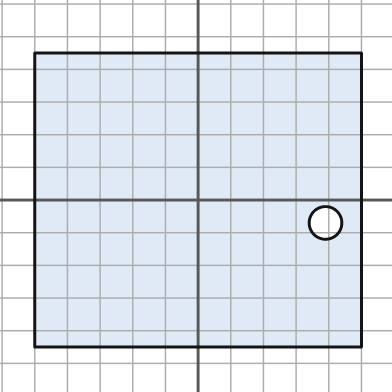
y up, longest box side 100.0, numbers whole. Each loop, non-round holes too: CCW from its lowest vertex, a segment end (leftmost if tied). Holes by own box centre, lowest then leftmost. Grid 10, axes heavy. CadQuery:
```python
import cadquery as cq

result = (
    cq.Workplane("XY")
    .moveTo(-50.0, -45.0)
    .lineTo(50.0, -45.0)
    .lineTo(50.0, 45.0)
    .lineTo(-50.0, 45.0)
    .close()
    .moveTo(39.0, -7.0)
    .circle(5.0)
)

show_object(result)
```